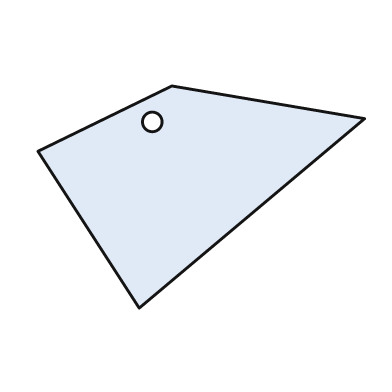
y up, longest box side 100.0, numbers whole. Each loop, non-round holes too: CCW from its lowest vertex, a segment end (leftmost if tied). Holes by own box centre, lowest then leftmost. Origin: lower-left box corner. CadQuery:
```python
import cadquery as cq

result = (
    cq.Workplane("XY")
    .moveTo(31.0, 0.0)
    .lineTo(100.0, 58.0)
    .lineTo(41.0, 68.0)
    .lineTo(0.0, 48.0)
    .close()
    .moveTo(35.0, 57.0)
    .circle(3.0)
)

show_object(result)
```